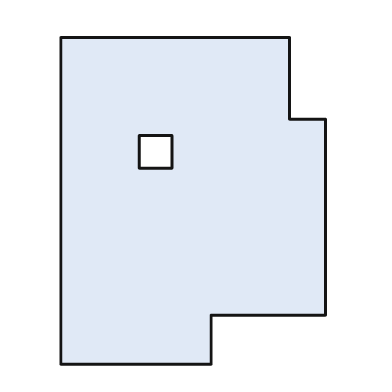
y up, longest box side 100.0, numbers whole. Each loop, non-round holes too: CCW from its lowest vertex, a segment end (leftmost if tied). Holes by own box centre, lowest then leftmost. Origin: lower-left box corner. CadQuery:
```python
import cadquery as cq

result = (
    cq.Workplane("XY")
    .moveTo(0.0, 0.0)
    .lineTo(46.0, 0.0)
    .lineTo(46.0, 15.0)
    .lineTo(81.0, 15.0)
    .lineTo(81.0, 75.0)
    .lineTo(70.0, 75.0)
    .lineTo(70.0, 100.0)
    .lineTo(0.0, 100.0)
    .close()
    .moveTo(24.0, 60.0)
    .lineTo(34.0, 60.0)
    .lineTo(34.0, 70.0)
    .lineTo(24.0, 70.0)
    .close()
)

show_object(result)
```